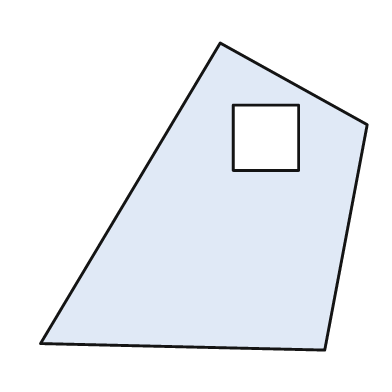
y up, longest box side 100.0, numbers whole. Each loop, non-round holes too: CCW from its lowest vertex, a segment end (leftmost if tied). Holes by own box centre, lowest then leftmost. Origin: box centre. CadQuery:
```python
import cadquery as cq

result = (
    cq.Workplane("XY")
    .moveTo(37.0, -47.0)
    .lineTo(50.0, 22.0)
    .lineTo(5.0, 47.0)
    .lineTo(-50.0, -45.0)
    .close()
    .moveTo(9.0, 8.0)
    .lineTo(29.0, 8.0)
    .lineTo(29.0, 28.0)
    .lineTo(9.0, 28.0)
    .close()
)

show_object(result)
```